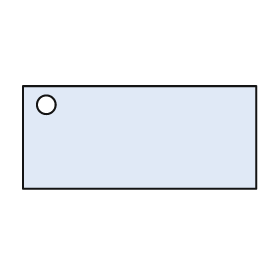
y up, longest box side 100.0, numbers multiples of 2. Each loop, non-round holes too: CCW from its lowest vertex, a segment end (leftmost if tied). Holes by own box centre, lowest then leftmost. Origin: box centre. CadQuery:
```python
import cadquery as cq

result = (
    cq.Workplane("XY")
    .moveTo(-50.0, -22.0)
    .lineTo(50.0, -22.0)
    .lineTo(50.0, 22.0)
    .lineTo(-50.0, 22.0)
    .close()
    .moveTo(-40.0, 14.0)
    .circle(4.0)
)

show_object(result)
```